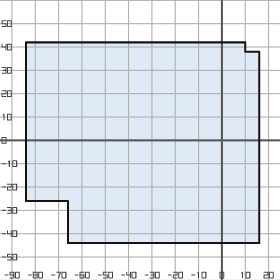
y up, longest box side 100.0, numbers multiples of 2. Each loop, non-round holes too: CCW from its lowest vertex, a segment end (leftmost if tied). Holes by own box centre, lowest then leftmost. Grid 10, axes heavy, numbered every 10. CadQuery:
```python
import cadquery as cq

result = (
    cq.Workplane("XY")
    .moveTo(-66.0, -44.0)
    .lineTo(16.0, -44.0)
    .lineTo(16.0, 38.0)
    .lineTo(10.0, 38.0)
    .lineTo(10.0, 42.0)
    .lineTo(-84.0, 42.0)
    .lineTo(-84.0, -26.0)
    .lineTo(-66.0, -26.0)
    .close()
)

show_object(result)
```